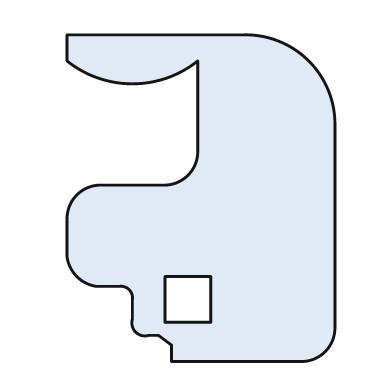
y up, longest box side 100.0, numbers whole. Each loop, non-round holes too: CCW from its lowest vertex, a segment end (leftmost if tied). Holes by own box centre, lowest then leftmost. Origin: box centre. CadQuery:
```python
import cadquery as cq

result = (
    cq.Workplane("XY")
    .moveTo(-9.0, -50.0)
    .lineTo(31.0, -50.0)
    .threePointArc((38.0, -47.0), (41.0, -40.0))
    .lineTo(41.0, 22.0)
    .threePointArc((33.0, 42.0), (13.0, 50.0))
    .lineTo(-41.0, 50.0)
    .lineTo(-41.0, 42.0)
    .threePointArc((-21.0, 35.0), (-1.0, 42.0))
    .lineTo(-1.0, 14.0)
    .threePointArc((-4.0, 7.0), (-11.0, 4.0))
    .lineTo(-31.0, 4.0)
    .threePointArc((-38.0, 1.0), (-41.0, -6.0))
    .lineTo(-41.0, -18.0)
    .threePointArc((-38.0, -24.0), (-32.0, -27.0))
    .lineTo(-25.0, -27.0)
    .threePointArc((-22.0, -28.0), (-21.0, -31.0))
    .lineTo(-21.0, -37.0)
    .threePointArc((-20.0, -41.0), (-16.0, -42.0))
    .lineTo(-13.0, -42.0)
    .lineTo(-9.0, -45.0)
    .close()
    .moveTo(-11.0, -38.0)
    .lineTo(3.0, -38.0)
    .lineTo(3.0, -24.0)
    .lineTo(-11.0, -24.0)
    .close()
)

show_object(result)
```